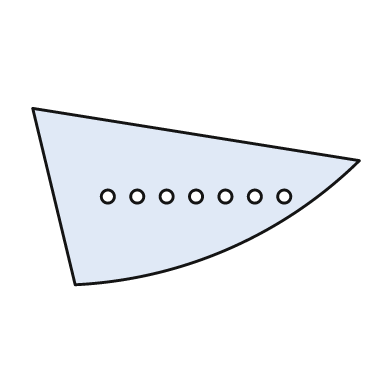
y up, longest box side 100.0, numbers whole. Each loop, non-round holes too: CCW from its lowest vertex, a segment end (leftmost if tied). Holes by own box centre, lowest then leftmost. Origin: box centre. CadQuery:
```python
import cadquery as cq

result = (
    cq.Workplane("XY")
    .moveTo(-37.0, -27.0)
    .threePointArc((10.0, -16.0), (50.0, 11.0))
    .lineTo(-50.0, 27.0)
    .close()
    .moveTo(-27.0, 0.0)
    .circle(2.0)
    .moveTo(-18.0, 0.0)
    .circle(2.0)
    .moveTo(-9.0, 0.0)
    .circle(2.0)
    .moveTo(0.0, 0.0)
    .circle(2.0)
    .moveTo(9.0, 0.0)
    .circle(2.0)
    .moveTo(18.0, 0.0)
    .circle(2.0)
    .moveTo(27.0, 0.0)
    .circle(2.0)
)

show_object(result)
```